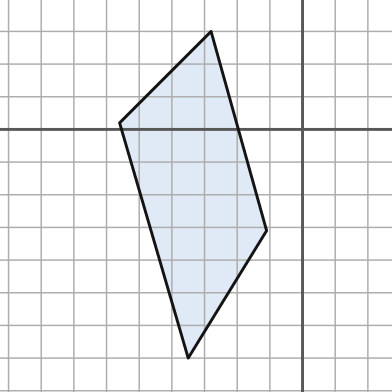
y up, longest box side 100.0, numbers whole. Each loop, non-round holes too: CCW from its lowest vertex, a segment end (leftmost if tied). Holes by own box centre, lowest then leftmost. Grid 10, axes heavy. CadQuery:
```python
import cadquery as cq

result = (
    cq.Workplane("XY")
    .moveTo(-35.0, -70.0)
    .lineTo(-11.0, -31.0)
    .lineTo(-28.0, 30.0)
    .lineTo(-56.0, 2.0)
    .close()
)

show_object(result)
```